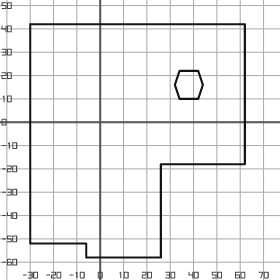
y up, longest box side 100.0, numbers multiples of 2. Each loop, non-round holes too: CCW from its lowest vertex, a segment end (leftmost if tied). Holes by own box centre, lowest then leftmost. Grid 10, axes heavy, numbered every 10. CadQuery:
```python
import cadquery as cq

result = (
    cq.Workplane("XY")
    .moveTo(-6.0, -58.0)
    .lineTo(26.0, -58.0)
    .lineTo(26.0, -18.0)
    .lineTo(62.0, -18.0)
    .lineTo(62.0, 42.0)
    .lineTo(-30.0, 42.0)
    .lineTo(-30.0, -52.0)
    .lineTo(-6.0, -52.0)
    .close()
    .moveTo(34.0, 10.0)
    .lineTo(42.0, 10.0)
    .lineTo(44.0, 16.0)
    .lineTo(42.0, 22.0)
    .lineTo(34.0, 22.0)
    .lineTo(32.0, 16.0)
    .close()
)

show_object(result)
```